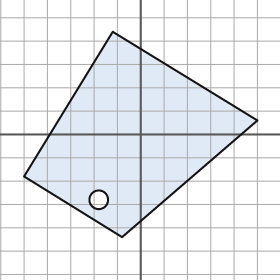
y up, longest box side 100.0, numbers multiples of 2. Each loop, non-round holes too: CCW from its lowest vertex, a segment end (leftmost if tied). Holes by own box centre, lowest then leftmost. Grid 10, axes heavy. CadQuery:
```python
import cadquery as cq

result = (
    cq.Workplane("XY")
    .moveTo(-8.0, -44.0)
    .lineTo(50.0, 6.0)
    .lineTo(-12.0, 44.0)
    .lineTo(-50.0, -18.0)
    .close()
    .moveTo(-18.0, -28.0)
    .circle(4.0)
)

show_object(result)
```